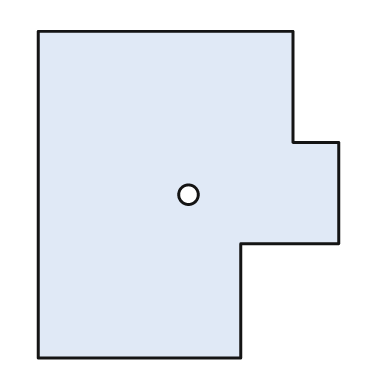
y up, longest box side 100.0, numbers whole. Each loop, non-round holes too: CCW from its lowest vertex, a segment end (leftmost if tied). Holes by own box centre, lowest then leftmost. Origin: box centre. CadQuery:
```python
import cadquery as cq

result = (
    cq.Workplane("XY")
    .moveTo(-46.0, -50.0)
    .lineTo(16.0, -50.0)
    .lineTo(16.0, -15.0)
    .lineTo(46.0, -15.0)
    .lineTo(46.0, 16.0)
    .lineTo(32.0, 16.0)
    .lineTo(32.0, 50.0)
    .lineTo(-46.0, 50.0)
    .close()
    .moveTo(0.0, 0.0)
    .circle(3.0)
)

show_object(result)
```